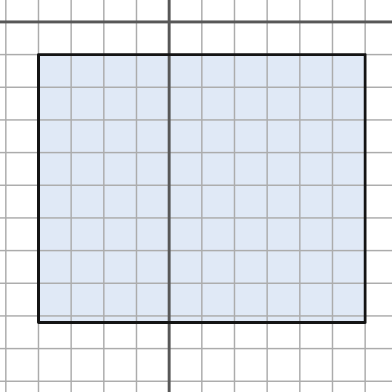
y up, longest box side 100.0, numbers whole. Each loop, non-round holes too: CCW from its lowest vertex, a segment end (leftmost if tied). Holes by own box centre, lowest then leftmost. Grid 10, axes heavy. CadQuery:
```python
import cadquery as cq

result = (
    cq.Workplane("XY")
    .moveTo(-40.0, -92.0)
    .lineTo(60.0, -92.0)
    .lineTo(60.0, -10.0)
    .lineTo(-40.0, -10.0)
    .close()
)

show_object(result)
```